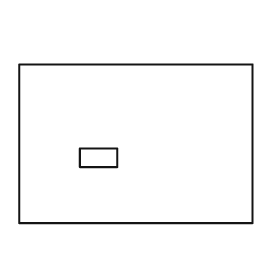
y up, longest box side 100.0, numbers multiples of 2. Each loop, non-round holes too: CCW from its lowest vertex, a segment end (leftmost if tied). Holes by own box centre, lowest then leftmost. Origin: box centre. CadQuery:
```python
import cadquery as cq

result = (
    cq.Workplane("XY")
    .moveTo(-50.0, -34.0)
    .lineTo(50.0, -34.0)
    .lineTo(50.0, 34.0)
    .lineTo(-50.0, 34.0)
    .close()
    .moveTo(-24.0, -10.0)
    .lineTo(-8.0, -10.0)
    .lineTo(-8.0, -2.0)
    .lineTo(-24.0, -2.0)
    .close()
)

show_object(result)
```